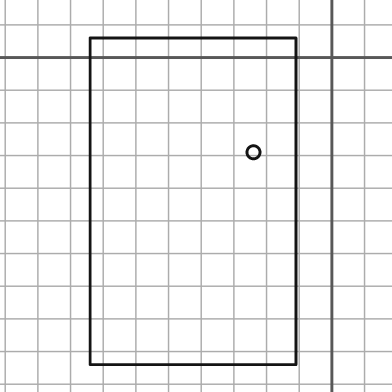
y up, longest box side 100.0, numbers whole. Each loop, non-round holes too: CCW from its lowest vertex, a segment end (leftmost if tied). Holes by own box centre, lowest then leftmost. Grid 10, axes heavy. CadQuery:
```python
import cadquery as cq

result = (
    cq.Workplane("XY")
    .moveTo(-74.0, -94.0)
    .lineTo(-11.0, -94.0)
    .lineTo(-11.0, 6.0)
    .lineTo(-74.0, 6.0)
    .close()
    .moveTo(-24.0, -29.0)
    .circle(2.0)
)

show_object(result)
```